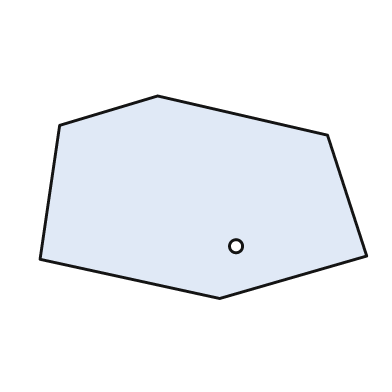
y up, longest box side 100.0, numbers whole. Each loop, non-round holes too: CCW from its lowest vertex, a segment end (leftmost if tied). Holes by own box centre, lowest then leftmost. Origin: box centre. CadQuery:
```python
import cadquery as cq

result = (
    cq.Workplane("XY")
    .moveTo(5.0, -31.0)
    .lineTo(50.0, -18.0)
    .lineTo(38.0, 19.0)
    .lineTo(-14.0, 31.0)
    .lineTo(-44.0, 22.0)
    .lineTo(-50.0, -19.0)
    .close()
    .moveTo(10.0, -15.0)
    .circle(2.0)
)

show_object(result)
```